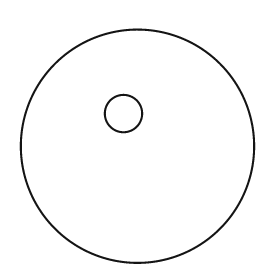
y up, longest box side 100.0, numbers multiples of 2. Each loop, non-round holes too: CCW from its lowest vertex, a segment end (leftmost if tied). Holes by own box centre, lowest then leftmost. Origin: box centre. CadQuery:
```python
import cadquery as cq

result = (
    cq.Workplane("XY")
    .moveTo(0.0, 0.0)
    .circle(50.0)
    .moveTo(-6.0, 14.0)
    .circle(8.0)
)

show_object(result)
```